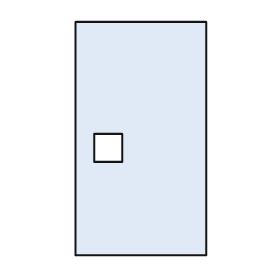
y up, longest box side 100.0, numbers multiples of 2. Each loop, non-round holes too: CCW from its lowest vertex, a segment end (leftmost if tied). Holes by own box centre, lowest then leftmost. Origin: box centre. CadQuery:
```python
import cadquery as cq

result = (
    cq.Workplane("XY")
    .moveTo(-28.0, -50.0)
    .lineTo(28.0, -50.0)
    .lineTo(28.0, 50.0)
    .lineTo(-28.0, 50.0)
    .close()
    .moveTo(-20.0, -10.0)
    .lineTo(-8.0, -10.0)
    .lineTo(-8.0, 2.0)
    .lineTo(-20.0, 2.0)
    .close()
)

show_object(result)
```